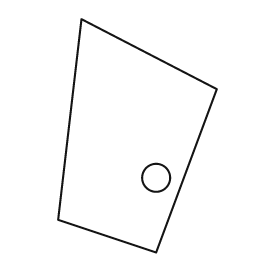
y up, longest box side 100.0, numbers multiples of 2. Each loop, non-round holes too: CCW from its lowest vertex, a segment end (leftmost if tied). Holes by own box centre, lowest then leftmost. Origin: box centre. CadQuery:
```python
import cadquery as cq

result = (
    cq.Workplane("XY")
    .moveTo(8.0, -50.0)
    .lineTo(34.0, 20.0)
    .lineTo(-24.0, 50.0)
    .lineTo(-34.0, -36.0)
    .close()
    .moveTo(8.0, -18.0)
    .circle(6.0)
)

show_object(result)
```